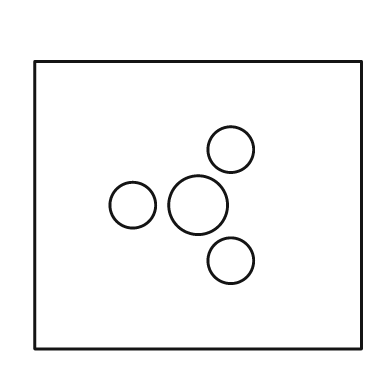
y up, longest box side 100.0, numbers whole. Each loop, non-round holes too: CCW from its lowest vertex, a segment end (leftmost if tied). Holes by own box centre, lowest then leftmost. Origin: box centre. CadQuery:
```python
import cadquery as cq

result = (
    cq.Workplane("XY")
    .moveTo(-50.0, -44.0)
    .lineTo(50.0, -44.0)
    .lineTo(50.0, 44.0)
    .lineTo(-50.0, 44.0)
    .close()
    .moveTo(10.0, -17.0)
    .circle(7.0)
    .moveTo(-20.0, 0.0)
    .circle(7.0)
    .moveTo(0.0, 0.0)
    .circle(9.0)
    .moveTo(10.0, 17.0)
    .circle(7.0)
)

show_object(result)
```